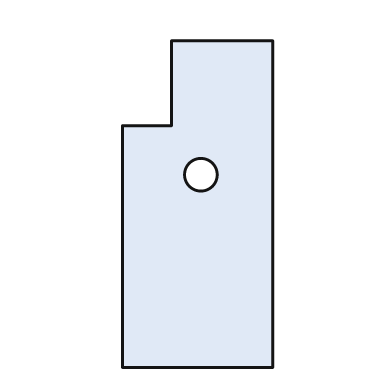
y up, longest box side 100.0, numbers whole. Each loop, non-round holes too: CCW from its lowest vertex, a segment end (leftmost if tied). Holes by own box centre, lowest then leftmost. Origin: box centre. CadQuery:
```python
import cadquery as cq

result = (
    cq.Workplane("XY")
    .moveTo(-23.0, -50.0)
    .lineTo(23.0, -50.0)
    .lineTo(23.0, 50.0)
    .lineTo(-8.0, 50.0)
    .lineTo(-8.0, 24.0)
    .lineTo(-23.0, 24.0)
    .close()
    .moveTo(1.0, 9.0)
    .circle(5.0)
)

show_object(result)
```